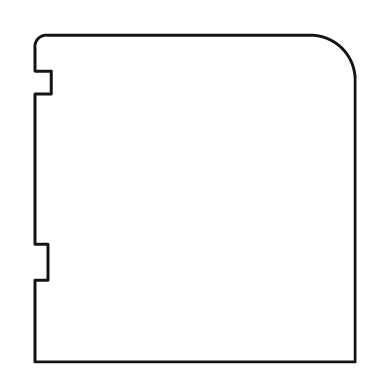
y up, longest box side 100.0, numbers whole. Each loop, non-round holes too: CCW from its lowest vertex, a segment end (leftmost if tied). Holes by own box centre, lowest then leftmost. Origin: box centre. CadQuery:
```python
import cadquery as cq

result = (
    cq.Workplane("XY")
    .moveTo(-49.0, -50.0)
    .lineTo(49.0, -50.0)
    .lineTo(49.0, 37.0)
    .threePointArc((45.0, 46.0), (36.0, 50.0))
    .lineTo(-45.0, 50.0)
    .threePointArc((-48.0, 49.0), (-49.0, 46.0))
    .lineTo(-49.0, 39.0)
    .lineTo(-44.0, 39.0)
    .lineTo(-44.0, 32.0)
    .lineTo(-49.0, 32.0)
    .lineTo(-49.0, -14.0)
    .lineTo(-45.0, -14.0)
    .lineTo(-45.0, -25.0)
    .lineTo(-49.0, -25.0)
    .close()
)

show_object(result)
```